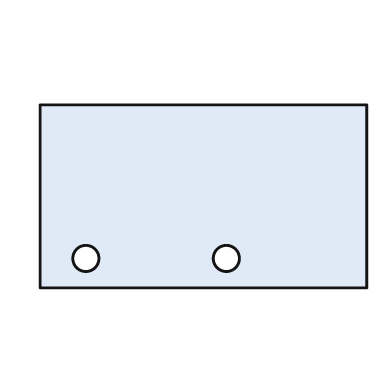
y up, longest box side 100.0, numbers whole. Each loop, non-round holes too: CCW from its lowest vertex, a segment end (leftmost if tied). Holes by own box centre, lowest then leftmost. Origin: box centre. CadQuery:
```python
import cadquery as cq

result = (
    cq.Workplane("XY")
    .moveTo(-50.0, -28.0)
    .lineTo(50.0, -28.0)
    .lineTo(50.0, 28.0)
    .lineTo(-50.0, 28.0)
    .close()
    .moveTo(-36.0, -19.0)
    .circle(4.0)
    .moveTo(7.0, -19.0)
    .circle(4.0)
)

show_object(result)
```